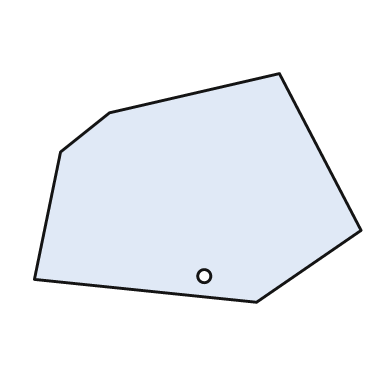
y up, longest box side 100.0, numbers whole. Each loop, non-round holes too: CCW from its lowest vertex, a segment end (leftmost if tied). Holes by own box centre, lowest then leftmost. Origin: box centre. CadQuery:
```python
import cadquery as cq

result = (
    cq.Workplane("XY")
    .moveTo(18.0, -35.0)
    .lineTo(50.0, -13.0)
    .lineTo(25.0, 35.0)
    .lineTo(-27.0, 23.0)
    .lineTo(-42.0, 11.0)
    .lineTo(-50.0, -28.0)
    .close()
    .moveTo(2.0, -27.0)
    .circle(2.0)
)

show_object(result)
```